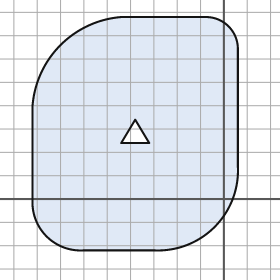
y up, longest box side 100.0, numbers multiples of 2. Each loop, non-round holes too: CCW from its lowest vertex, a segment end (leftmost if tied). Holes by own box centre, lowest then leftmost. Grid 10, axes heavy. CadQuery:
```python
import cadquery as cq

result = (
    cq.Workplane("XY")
    .moveTo(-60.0, -22.0)
    .lineTo(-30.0, -22.0)
    .threePointArc((-4.0, -12.0), (6.0, 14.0))
    .lineTo(6.0, 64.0)
    .threePointArc((2.0, 74.0), (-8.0, 78.0))
    .lineTo(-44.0, 78.0)
    .threePointArc((-70.0, 66.0), (-82.0, 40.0))
    .lineTo(-82.0, 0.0)
    .threePointArc((-76.0, -16.0), (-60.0, -22.0))
    .close()
    .moveTo(-44.0, 24.0)
    .lineTo(-32.0, 24.0)
    .lineTo(-38.0, 34.0)
    .close()
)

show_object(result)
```